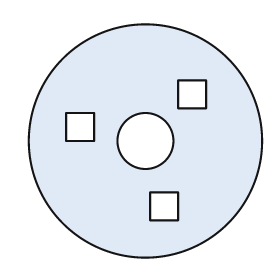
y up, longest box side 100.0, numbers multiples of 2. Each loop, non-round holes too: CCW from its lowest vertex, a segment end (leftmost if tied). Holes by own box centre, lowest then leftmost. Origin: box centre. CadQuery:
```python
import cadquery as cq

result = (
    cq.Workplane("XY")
    .moveTo(0.0, 0.0)
    .circle(50.0)
    .moveTo(2.0, -34.0)
    .lineTo(14.0, -34.0)
    .lineTo(14.0, -22.0)
    .lineTo(2.0, -22.0)
    .close()
    .moveTo(0.0, 0.0)
    .circle(12.0)
    .moveTo(-34.0, 0.0)
    .lineTo(-22.0, 0.0)
    .lineTo(-22.0, 12.0)
    .lineTo(-34.0, 12.0)
    .close()
    .moveTo(14.0, 14.0)
    .lineTo(26.0, 14.0)
    .lineTo(26.0, 26.0)
    .lineTo(14.0, 26.0)
    .close()
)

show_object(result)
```